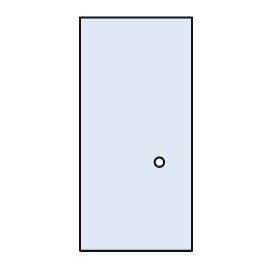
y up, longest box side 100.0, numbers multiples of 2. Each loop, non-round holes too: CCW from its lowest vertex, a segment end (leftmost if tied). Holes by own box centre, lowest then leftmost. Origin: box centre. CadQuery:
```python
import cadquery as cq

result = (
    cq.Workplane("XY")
    .moveTo(-24.0, -50.0)
    .lineTo(24.0, -50.0)
    .lineTo(24.0, 50.0)
    .lineTo(-24.0, 50.0)
    .close()
    .moveTo(10.0, -12.0)
    .circle(2.0)
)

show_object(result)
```